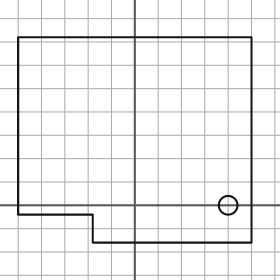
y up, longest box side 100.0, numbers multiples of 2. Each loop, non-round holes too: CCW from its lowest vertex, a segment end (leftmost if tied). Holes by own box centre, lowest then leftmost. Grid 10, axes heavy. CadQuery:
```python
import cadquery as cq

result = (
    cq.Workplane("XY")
    .moveTo(-18.0, -16.0)
    .lineTo(50.0, -16.0)
    .lineTo(50.0, 72.0)
    .lineTo(-50.0, 72.0)
    .lineTo(-50.0, -4.0)
    .lineTo(-18.0, -4.0)
    .close()
    .moveTo(40.0, 0.0)
    .circle(4.0)
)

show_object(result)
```